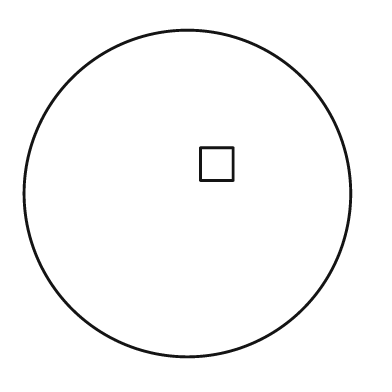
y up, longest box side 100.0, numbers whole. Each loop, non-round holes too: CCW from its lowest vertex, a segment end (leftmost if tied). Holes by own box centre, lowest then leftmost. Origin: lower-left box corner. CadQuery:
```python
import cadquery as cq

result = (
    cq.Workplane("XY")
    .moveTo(50.0, 50.0)
    .circle(50.0)
    .moveTo(54.0, 54.0)
    .lineTo(64.0, 54.0)
    .lineTo(64.0, 64.0)
    .lineTo(54.0, 64.0)
    .close()
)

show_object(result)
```